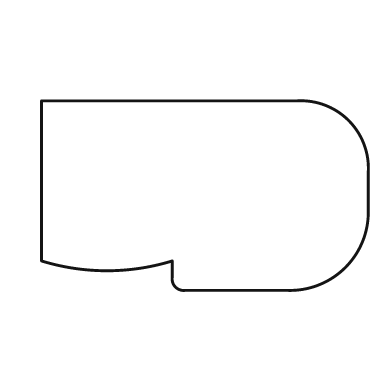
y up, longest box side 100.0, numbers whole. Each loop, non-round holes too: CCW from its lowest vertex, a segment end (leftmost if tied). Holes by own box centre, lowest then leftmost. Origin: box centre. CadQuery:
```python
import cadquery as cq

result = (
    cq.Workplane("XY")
    .moveTo(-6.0, -29.0)
    .lineTo(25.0, -29.0)
    .threePointArc((43.0, -22.0), (50.0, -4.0))
    .lineTo(50.0, 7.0)
    .threePointArc((44.0, 23.0), (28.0, 29.0))
    .lineTo(-50.0, 29.0)
    .lineTo(-50.0, -20.0)
    .threePointArc((-30.0, -23.0), (-10.0, -20.0))
    .lineTo(-10.0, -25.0)
    .threePointArc((-9.0, -28.0), (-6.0, -29.0))
    .close()
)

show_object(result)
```